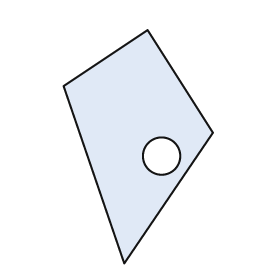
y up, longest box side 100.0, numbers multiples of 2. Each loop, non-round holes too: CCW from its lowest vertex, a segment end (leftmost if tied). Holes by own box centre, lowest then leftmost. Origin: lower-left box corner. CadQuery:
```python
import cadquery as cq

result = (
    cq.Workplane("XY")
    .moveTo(26.0, 0.0)
    .lineTo(64.0, 56.0)
    .lineTo(36.0, 100.0)
    .lineTo(0.0, 76.0)
    .close()
    .moveTo(42.0, 46.0)
    .circle(8.0)
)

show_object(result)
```